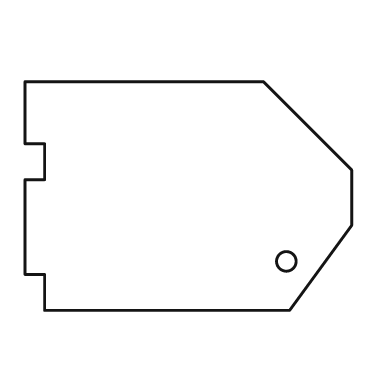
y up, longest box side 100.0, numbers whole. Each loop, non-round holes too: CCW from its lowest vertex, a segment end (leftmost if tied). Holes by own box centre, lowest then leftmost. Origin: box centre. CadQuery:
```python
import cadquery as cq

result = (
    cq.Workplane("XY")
    .moveTo(-44.0, -35.0)
    .lineTo(31.0, -35.0)
    .lineTo(50.0, -9.0)
    .lineTo(50.0, 8.0)
    .lineTo(23.0, 35.0)
    .lineTo(-50.0, 35.0)
    .lineTo(-50.0, 16.0)
    .lineTo(-44.0, 16.0)
    .lineTo(-44.0, 5.0)
    .lineTo(-50.0, 5.0)
    .lineTo(-50.0, -24.0)
    .lineTo(-44.0, -24.0)
    .close()
    .moveTo(30.0, -20.0)
    .circle(3.0)
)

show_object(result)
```